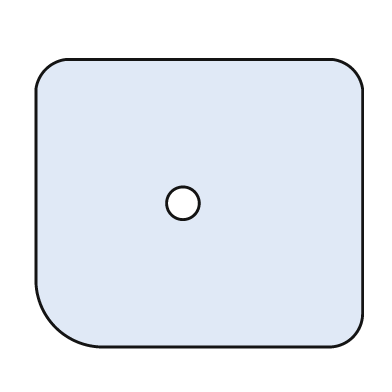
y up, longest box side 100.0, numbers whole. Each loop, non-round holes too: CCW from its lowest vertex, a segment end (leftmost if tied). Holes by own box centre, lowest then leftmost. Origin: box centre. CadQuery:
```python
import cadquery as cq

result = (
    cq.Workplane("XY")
    .moveTo(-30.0, -44.0)
    .lineTo(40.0, -44.0)
    .threePointArc((47.0, -41.0), (50.0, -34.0))
    .lineTo(50.0, 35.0)
    .threePointArc((47.0, 41.0), (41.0, 44.0))
    .lineTo(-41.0, 44.0)
    .threePointArc((-47.0, 41.0), (-50.0, 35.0))
    .lineTo(-50.0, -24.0)
    .threePointArc((-44.0, -38.0), (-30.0, -44.0))
    .close()
    .moveTo(-5.0, 0.0)
    .circle(5.0)
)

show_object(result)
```